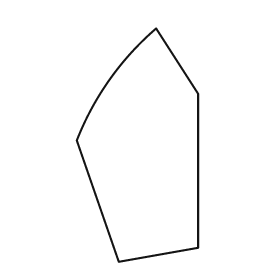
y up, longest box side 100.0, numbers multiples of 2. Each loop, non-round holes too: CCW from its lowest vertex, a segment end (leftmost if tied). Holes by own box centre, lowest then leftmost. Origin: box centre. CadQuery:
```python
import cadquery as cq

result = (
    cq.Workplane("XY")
    .moveTo(-8.0, -50.0)
    .lineTo(26.0, -44.0)
    .lineTo(26.0, 22.0)
    .lineTo(8.0, 50.0)
    .threePointArc((-12.0, 28.0), (-26.0, 2.0))
    .close()
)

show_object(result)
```